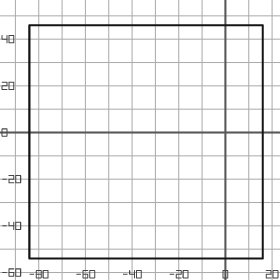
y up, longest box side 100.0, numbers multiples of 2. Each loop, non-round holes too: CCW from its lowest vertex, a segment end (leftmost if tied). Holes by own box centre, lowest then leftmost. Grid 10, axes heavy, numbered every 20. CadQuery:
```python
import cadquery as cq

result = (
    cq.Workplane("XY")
    .moveTo(-84.0, -54.0)
    .lineTo(16.0, -54.0)
    .lineTo(16.0, 46.0)
    .lineTo(-84.0, 46.0)
    .close()
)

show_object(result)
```